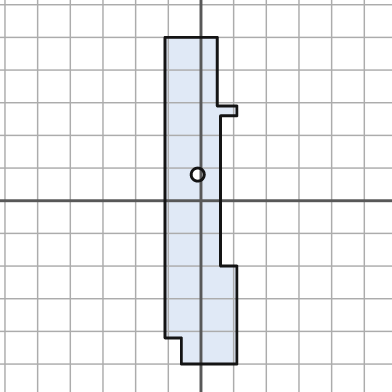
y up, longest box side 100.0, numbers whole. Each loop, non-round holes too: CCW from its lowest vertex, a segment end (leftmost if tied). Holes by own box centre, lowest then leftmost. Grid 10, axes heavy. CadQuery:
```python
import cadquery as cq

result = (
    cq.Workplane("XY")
    .moveTo(-6.0, -50.0)
    .lineTo(11.0, -50.0)
    .lineTo(11.0, -20.0)
    .lineTo(6.0, -20.0)
    .lineTo(6.0, 26.0)
    .lineTo(11.0, 26.0)
    .lineTo(11.0, 29.0)
    .lineTo(5.0, 29.0)
    .lineTo(5.0, 50.0)
    .lineTo(-11.0, 50.0)
    .lineTo(-11.0, -42.0)
    .lineTo(-6.0, -42.0)
    .close()
    .moveTo(-1.0, 8.0)
    .circle(2.0)
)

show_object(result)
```